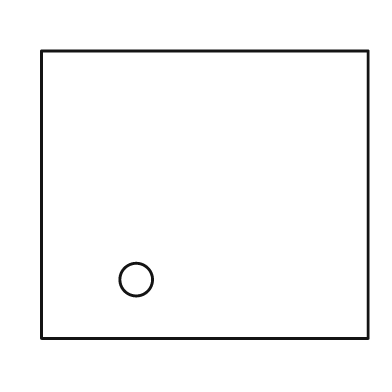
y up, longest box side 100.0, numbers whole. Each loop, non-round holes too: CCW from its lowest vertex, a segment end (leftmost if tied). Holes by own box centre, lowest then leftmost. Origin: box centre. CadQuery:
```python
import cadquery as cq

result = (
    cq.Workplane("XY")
    .moveTo(-50.0, -44.0)
    .lineTo(50.0, -44.0)
    .lineTo(50.0, 44.0)
    .lineTo(-50.0, 44.0)
    .close()
    .moveTo(-21.0, -26.0)
    .circle(5.0)
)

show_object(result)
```